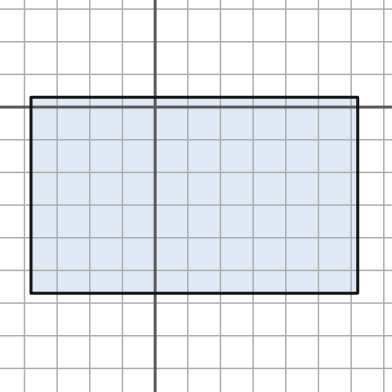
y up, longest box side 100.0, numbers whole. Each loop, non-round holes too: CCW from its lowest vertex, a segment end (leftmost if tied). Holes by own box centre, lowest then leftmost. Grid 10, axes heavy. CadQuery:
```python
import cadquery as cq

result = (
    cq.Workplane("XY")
    .moveTo(-38.0, -57.0)
    .lineTo(62.0, -57.0)
    .lineTo(62.0, 3.0)
    .lineTo(-38.0, 3.0)
    .close()
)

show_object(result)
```